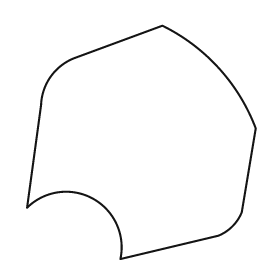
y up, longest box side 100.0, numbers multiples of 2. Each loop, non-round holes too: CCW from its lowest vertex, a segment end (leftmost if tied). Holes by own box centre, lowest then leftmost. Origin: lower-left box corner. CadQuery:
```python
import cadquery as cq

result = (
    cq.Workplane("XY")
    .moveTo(40.0, 0.0)
    .lineTo(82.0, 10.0)
    .threePointArc((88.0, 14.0), (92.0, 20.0))
    .lineTo(98.0, 56.0)
    .threePointArc((82.0, 82.0), (58.0, 100.0))
    .lineTo(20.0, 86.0)
    .threePointArc((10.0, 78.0), (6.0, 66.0))
    .lineTo(0.0, 22.0)
    .threePointArc((28.0, 26.0), (40.0, 0.0))
    .close()
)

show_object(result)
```